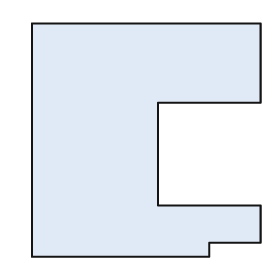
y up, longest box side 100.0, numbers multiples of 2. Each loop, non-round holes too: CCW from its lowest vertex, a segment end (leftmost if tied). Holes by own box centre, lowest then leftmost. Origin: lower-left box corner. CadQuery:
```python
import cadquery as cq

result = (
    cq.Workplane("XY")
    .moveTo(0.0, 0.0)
    .lineTo(76.0, 0.0)
    .lineTo(76.0, 6.0)
    .lineTo(98.0, 6.0)
    .lineTo(98.0, 22.0)
    .lineTo(54.0, 22.0)
    .lineTo(54.0, 66.0)
    .lineTo(98.0, 66.0)
    .lineTo(98.0, 100.0)
    .lineTo(0.0, 100.0)
    .close()
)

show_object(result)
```